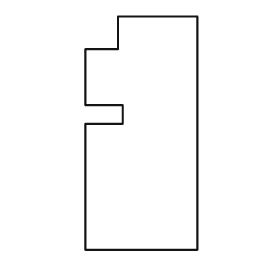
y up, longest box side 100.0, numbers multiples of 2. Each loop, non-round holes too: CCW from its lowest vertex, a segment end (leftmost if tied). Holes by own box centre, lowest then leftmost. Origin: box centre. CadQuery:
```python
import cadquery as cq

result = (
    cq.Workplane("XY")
    .moveTo(-24.0, -50.0)
    .lineTo(24.0, -50.0)
    .lineTo(24.0, 50.0)
    .lineTo(-10.0, 50.0)
    .lineTo(-10.0, 36.0)
    .lineTo(-24.0, 36.0)
    .lineTo(-24.0, 12.0)
    .lineTo(-8.0, 12.0)
    .lineTo(-8.0, 4.0)
    .lineTo(-24.0, 4.0)
    .close()
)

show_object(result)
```